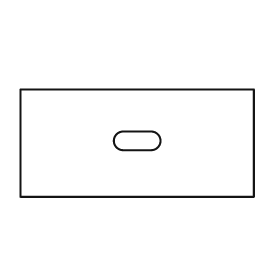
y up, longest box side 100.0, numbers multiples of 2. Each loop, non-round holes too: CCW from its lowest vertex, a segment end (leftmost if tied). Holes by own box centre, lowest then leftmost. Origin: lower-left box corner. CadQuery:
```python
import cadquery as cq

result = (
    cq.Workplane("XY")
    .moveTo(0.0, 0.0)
    .lineTo(100.0, 0.0)
    .lineTo(100.0, 46.0)
    .lineTo(0.0, 46.0)
    .close()
    .moveTo(44.0, 20.0)
    .lineTo(56.0, 20.0)
    .threePointArc((60.0, 24.0), (56.0, 28.0))
    .lineTo(44.0, 28.0)
    .threePointArc((40.0, 24.0), (44.0, 20.0))
    .close()
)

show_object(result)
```